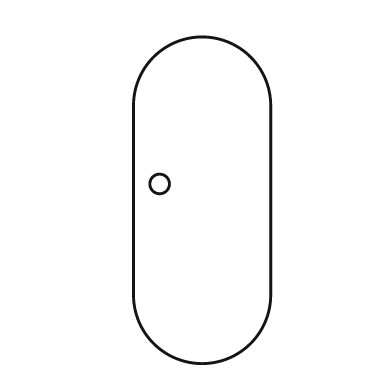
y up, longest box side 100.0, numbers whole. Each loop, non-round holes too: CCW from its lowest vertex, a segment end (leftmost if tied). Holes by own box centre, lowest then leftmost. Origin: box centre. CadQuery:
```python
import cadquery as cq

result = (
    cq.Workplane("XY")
    .moveTo(-21.0, -29.0)
    .threePointArc((0.0, -50.0), (21.0, -29.0))
    .lineTo(21.0, 29.0)
    .threePointArc((0.0, 50.0), (-21.0, 29.0))
    .close()
    .moveTo(-13.0, 5.0)
    .circle(3.0)
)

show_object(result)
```